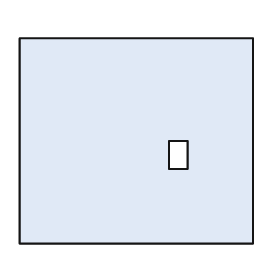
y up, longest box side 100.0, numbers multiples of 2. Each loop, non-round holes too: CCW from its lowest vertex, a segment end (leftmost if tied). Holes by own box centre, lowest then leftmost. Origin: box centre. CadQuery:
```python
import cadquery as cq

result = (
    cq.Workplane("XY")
    .moveTo(-50.0, -44.0)
    .lineTo(50.0, -44.0)
    .lineTo(50.0, 44.0)
    .lineTo(-50.0, 44.0)
    .close()
    .moveTo(14.0, -12.0)
    .lineTo(22.0, -12.0)
    .lineTo(22.0, 0.0)
    .lineTo(14.0, 0.0)
    .close()
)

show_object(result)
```